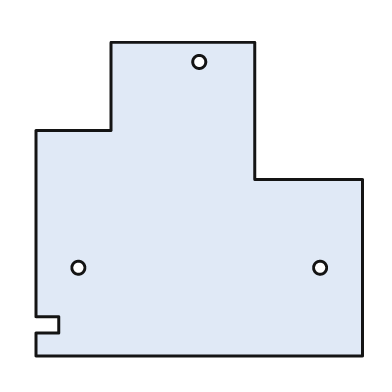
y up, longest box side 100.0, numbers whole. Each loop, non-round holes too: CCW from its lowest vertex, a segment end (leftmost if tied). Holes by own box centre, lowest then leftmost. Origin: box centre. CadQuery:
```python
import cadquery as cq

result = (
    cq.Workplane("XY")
    .moveTo(-50.0, -48.0)
    .lineTo(50.0, -48.0)
    .lineTo(50.0, 6.0)
    .lineTo(17.0, 6.0)
    .lineTo(17.0, 48.0)
    .lineTo(-27.0, 48.0)
    .lineTo(-27.0, 21.0)
    .lineTo(-50.0, 21.0)
    .lineTo(-50.0, -36.0)
    .lineTo(-43.0, -36.0)
    .lineTo(-43.0, -41.0)
    .lineTo(-50.0, -41.0)
    .close()
    .moveTo(-37.0, -21.0)
    .circle(2.0)
    .moveTo(37.0, -21.0)
    .circle(2.0)
    .moveTo(0.0, 42.0)
    .circle(2.0)
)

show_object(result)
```